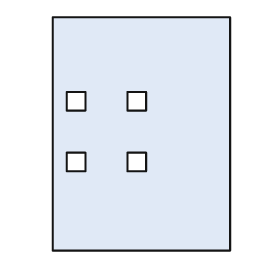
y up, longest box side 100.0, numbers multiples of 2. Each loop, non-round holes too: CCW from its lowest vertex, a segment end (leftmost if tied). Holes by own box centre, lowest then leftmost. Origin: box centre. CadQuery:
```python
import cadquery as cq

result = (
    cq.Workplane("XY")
    .moveTo(-38.0, -50.0)
    .lineTo(38.0, -50.0)
    .lineTo(38.0, 50.0)
    .lineTo(-38.0, 50.0)
    .close()
    .moveTo(-32.0, -16.0)
    .lineTo(-24.0, -16.0)
    .lineTo(-24.0, -8.0)
    .lineTo(-32.0, -8.0)
    .close()
    .moveTo(-6.0, -16.0)
    .lineTo(2.0, -16.0)
    .lineTo(2.0, -8.0)
    .lineTo(-6.0, -8.0)
    .close()
    .moveTo(-32.0, 10.0)
    .lineTo(-24.0, 10.0)
    .lineTo(-24.0, 18.0)
    .lineTo(-32.0, 18.0)
    .close()
    .moveTo(-6.0, 10.0)
    .lineTo(2.0, 10.0)
    .lineTo(2.0, 18.0)
    .lineTo(-6.0, 18.0)
    .close()
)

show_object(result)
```